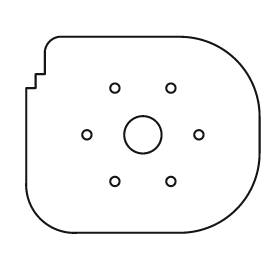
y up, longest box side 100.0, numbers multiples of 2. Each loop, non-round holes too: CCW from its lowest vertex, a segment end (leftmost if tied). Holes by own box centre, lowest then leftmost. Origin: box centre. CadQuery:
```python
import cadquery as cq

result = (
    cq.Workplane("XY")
    .moveTo(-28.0, -42.0)
    .lineTo(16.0, -42.0)
    .threePointArc((40.0, -32.0), (50.0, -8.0))
    .lineTo(50.0, 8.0)
    .threePointArc((40.0, 32.0), (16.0, 42.0))
    .lineTo(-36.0, 42.0)
    .threePointArc((-40.0, 40.0), (-42.0, 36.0))
    .lineTo(-42.0, 26.0)
    .lineTo(-46.0, 26.0)
    .lineTo(-46.0, 20.0)
    .lineTo(-50.0, 20.0)
    .lineTo(-50.0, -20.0)
    .threePointArc((-44.0, -36.0), (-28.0, -42.0))
    .close()
    .moveTo(-12.0, -20.0)
    .circle(2.0)
    .moveTo(12.0, -20.0)
    .circle(2.0)
    .moveTo(-24.0, 0.0)
    .circle(2.0)
    .moveTo(0.0, 0.0)
    .circle(8.0)
    .moveTo(24.0, 0.0)
    .circle(2.0)
    .moveTo(-12.0, 20.0)
    .circle(2.0)
    .moveTo(12.0, 20.0)
    .circle(2.0)
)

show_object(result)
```